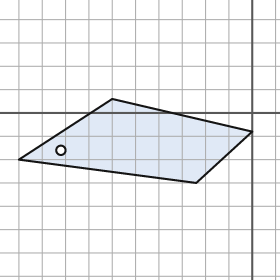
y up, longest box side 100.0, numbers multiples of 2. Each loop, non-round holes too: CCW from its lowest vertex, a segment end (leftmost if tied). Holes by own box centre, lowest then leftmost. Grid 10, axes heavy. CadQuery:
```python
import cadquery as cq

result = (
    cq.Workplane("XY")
    .moveTo(-24.0, -30.0)
    .lineTo(0.0, -8.0)
    .lineTo(-60.0, 6.0)
    .lineTo(-100.0, -20.0)
    .close()
    .moveTo(-82.0, -16.0)
    .circle(2.0)
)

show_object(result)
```